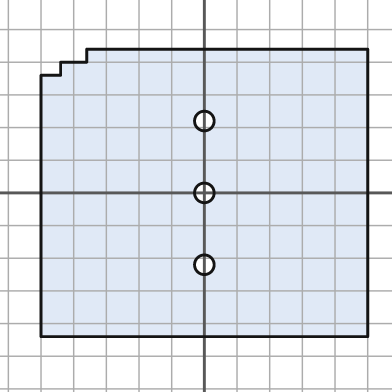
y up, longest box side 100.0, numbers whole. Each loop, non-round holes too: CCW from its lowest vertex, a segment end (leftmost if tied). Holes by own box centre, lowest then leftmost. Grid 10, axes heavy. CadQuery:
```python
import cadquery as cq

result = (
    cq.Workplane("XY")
    .moveTo(-50.0, -44.0)
    .lineTo(50.0, -44.0)
    .lineTo(50.0, 44.0)
    .lineTo(-36.0, 44.0)
    .lineTo(-36.0, 40.0)
    .lineTo(-44.0, 40.0)
    .lineTo(-44.0, 36.0)
    .lineTo(-50.0, 36.0)
    .close()
    .moveTo(0.0, -22.0)
    .circle(3.0)
    .moveTo(0.0, 0.0)
    .circle(3.0)
    .moveTo(0.0, 22.0)
    .circle(3.0)
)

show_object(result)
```